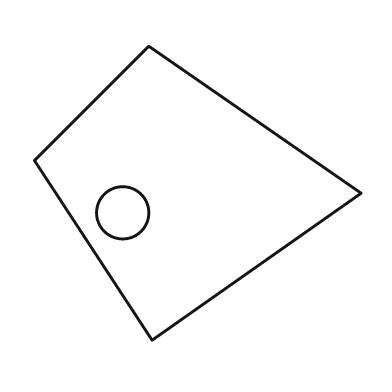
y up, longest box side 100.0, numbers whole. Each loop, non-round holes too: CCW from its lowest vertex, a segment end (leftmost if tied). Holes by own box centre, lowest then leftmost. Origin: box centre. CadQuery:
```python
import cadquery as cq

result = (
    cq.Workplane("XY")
    .moveTo(-14.0, -45.0)
    .lineTo(50.0, 0.0)
    .lineTo(-15.0, 45.0)
    .lineTo(-50.0, 10.0)
    .close()
    .moveTo(-23.0, -6.0)
    .circle(8.0)
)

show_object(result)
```